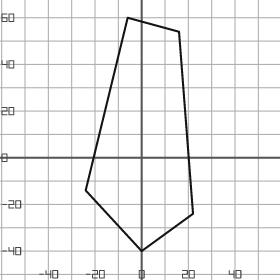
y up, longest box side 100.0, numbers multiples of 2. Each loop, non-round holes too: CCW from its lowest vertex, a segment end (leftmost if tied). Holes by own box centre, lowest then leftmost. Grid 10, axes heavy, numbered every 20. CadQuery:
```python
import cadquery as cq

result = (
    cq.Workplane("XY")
    .moveTo(0.0, -40.0)
    .lineTo(22.0, -24.0)
    .lineTo(16.0, 54.0)
    .lineTo(-6.0, 60.0)
    .lineTo(-24.0, -14.0)
    .close()
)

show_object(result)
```